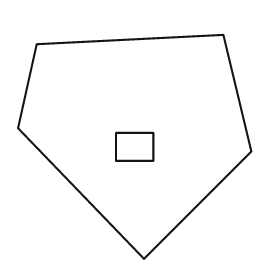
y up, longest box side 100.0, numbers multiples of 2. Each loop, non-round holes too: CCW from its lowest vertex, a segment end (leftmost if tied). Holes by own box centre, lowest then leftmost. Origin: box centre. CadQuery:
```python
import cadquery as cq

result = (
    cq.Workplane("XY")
    .moveTo(4.0, -48.0)
    .lineTo(50.0, -2.0)
    .lineTo(38.0, 48.0)
    .lineTo(-42.0, 44.0)
    .lineTo(-50.0, 8.0)
    .close()
    .moveTo(-8.0, -6.0)
    .lineTo(8.0, -6.0)
    .lineTo(8.0, 6.0)
    .lineTo(-8.0, 6.0)
    .close()
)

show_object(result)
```